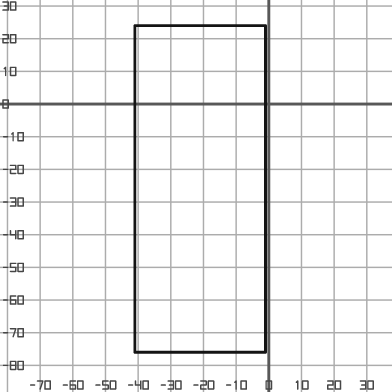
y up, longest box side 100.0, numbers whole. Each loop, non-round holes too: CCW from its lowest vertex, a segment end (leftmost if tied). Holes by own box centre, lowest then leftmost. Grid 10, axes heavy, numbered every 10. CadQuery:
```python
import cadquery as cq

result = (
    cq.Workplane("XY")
    .moveTo(-41.0, -76.0)
    .lineTo(-1.0, -76.0)
    .lineTo(-1.0, 24.0)
    .lineTo(-41.0, 24.0)
    .close()
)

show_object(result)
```